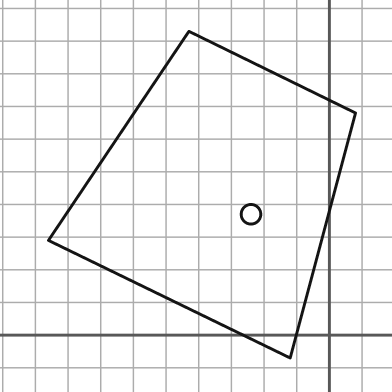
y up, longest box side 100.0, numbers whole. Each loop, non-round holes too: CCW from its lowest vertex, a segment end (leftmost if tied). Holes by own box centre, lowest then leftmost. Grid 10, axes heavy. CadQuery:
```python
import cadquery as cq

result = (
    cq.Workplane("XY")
    .moveTo(-12.0, -7.0)
    .lineTo(8.0, 68.0)
    .lineTo(-43.0, 93.0)
    .lineTo(-86.0, 29.0)
    .close()
    .moveTo(-24.0, 37.0)
    .circle(3.0)
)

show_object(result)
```